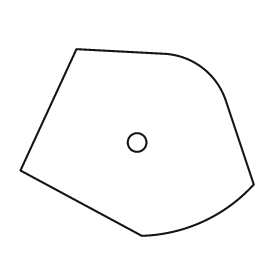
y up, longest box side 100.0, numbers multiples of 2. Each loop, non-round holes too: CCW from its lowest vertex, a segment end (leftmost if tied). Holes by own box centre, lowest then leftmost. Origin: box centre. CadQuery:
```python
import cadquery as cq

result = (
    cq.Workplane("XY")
    .moveTo(2.0, -40.0)
    .threePointArc((28.0, -34.0), (50.0, -18.0))
    .lineTo(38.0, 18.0)
    .threePointArc((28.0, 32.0), (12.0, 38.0))
    .lineTo(-26.0, 40.0)
    .lineTo(-50.0, -12.0)
    .close()
    .moveTo(0.0, 0.0)
    .circle(4.0)
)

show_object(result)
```